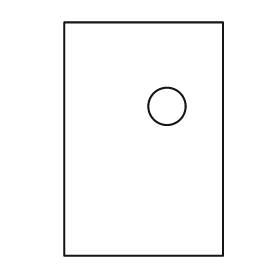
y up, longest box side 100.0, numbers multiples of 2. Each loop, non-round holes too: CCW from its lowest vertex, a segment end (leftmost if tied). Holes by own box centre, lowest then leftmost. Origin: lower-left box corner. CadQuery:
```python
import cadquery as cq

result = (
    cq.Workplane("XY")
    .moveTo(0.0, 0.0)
    .lineTo(68.0, 0.0)
    .lineTo(68.0, 100.0)
    .lineTo(0.0, 100.0)
    .close()
    .moveTo(44.0, 64.0)
    .circle(8.0)
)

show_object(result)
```